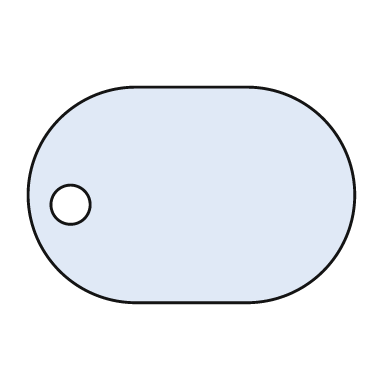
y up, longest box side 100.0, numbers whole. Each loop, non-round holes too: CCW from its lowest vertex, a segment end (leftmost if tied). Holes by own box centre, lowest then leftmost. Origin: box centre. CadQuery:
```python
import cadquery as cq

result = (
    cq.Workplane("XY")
    .moveTo(-17.0, -33.0)
    .lineTo(17.0, -33.0)
    .threePointArc((50.0, 0.0), (17.0, 33.0))
    .lineTo(-17.0, 33.0)
    .threePointArc((-50.0, 0.0), (-17.0, -33.0))
    .close()
    .moveTo(-37.0, -3.0)
    .circle(6.0)
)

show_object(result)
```